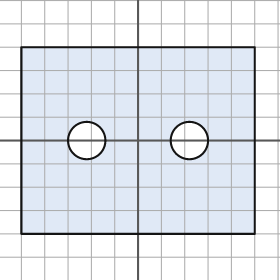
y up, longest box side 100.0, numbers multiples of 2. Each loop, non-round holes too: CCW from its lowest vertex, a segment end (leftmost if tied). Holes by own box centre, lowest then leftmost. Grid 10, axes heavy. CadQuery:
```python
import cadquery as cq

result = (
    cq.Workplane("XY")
    .moveTo(-50.0, -40.0)
    .lineTo(50.0, -40.0)
    .lineTo(50.0, 40.0)
    .lineTo(-50.0, 40.0)
    .close()
    .moveTo(-22.0, 0.0)
    .circle(8.0)
    .moveTo(22.0, 0.0)
    .circle(8.0)
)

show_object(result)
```